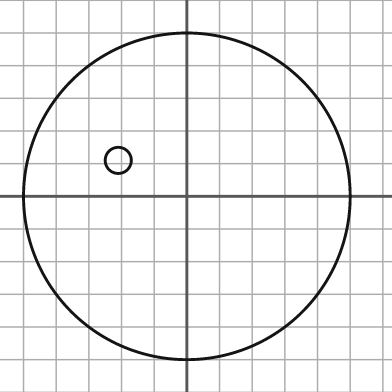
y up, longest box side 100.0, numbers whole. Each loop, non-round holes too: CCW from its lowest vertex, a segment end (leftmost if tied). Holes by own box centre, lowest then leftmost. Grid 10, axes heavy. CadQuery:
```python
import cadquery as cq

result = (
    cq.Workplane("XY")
    .moveTo(0.0, 0.0)
    .circle(50.0)
    .moveTo(-21.0, 11.0)
    .circle(4.0)
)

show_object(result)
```